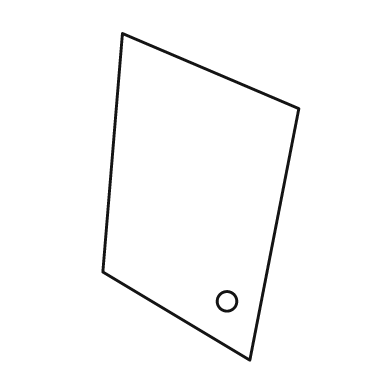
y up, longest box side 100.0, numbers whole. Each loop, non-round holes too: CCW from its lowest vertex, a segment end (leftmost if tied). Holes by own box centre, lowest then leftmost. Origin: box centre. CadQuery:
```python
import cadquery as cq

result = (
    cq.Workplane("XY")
    .moveTo(15.0, -50.0)
    .lineTo(30.0, 27.0)
    .lineTo(-24.0, 50.0)
    .lineTo(-30.0, -23.0)
    .close()
    .moveTo(8.0, -32.0)
    .circle(3.0)
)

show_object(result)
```